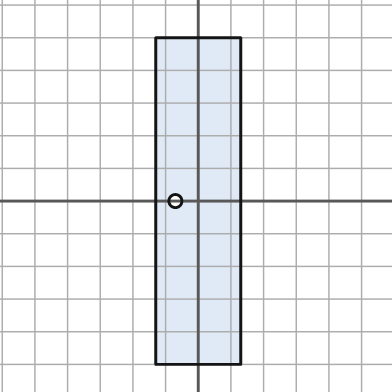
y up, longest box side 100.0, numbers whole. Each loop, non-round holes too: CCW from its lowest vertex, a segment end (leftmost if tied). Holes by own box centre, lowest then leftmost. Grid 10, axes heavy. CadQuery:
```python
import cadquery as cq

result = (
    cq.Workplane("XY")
    .moveTo(-13.0, -50.0)
    .lineTo(13.0, -50.0)
    .lineTo(13.0, 50.0)
    .lineTo(-13.0, 50.0)
    .close()
    .moveTo(-7.0, 0.0)
    .circle(2.0)
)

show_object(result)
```